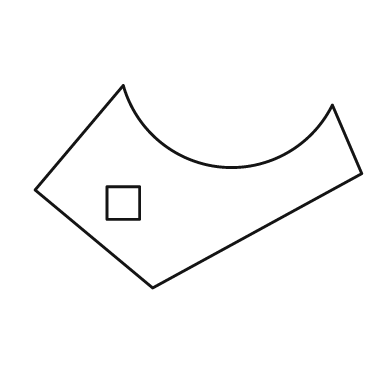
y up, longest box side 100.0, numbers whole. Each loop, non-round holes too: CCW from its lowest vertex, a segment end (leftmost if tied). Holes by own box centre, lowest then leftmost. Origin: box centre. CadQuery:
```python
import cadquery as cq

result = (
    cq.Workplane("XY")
    .moveTo(-14.0, -31.0)
    .lineTo(50.0, 4.0)
    .lineTo(41.0, 25.0)
    .threePointArc((7.0, 6.0), (-23.0, 31.0))
    .lineTo(-50.0, -1.0)
    .close()
    .moveTo(-28.0, -10.0)
    .lineTo(-18.0, -10.0)
    .lineTo(-18.0, 0.0)
    .lineTo(-28.0, 0.0)
    .close()
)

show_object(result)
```